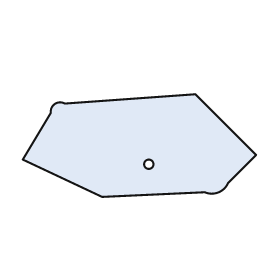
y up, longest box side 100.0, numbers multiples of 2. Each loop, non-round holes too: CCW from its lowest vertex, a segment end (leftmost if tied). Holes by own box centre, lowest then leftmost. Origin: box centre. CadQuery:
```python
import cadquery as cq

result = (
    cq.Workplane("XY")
    .moveTo(-16.0, -22.0)
    .lineTo(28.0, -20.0)
    .threePointArc((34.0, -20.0), (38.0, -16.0))
    .lineTo(50.0, -4.0)
    .lineTo(24.0, 22.0)
    .lineTo(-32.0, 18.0)
    .threePointArc((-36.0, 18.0), (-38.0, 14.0))
    .lineTo(-50.0, -6.0)
    .close()
    .moveTo(4.0, -8.0)
    .circle(2.0)
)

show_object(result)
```